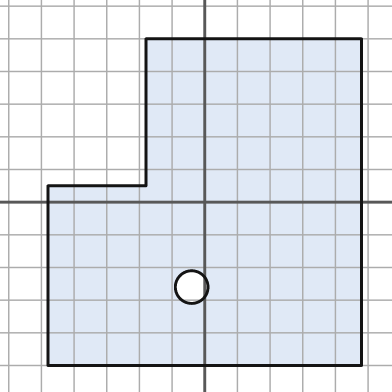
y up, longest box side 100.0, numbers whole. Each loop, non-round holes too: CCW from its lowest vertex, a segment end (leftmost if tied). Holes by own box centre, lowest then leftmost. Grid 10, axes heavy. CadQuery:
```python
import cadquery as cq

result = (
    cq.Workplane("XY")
    .moveTo(-48.0, -50.0)
    .lineTo(48.0, -50.0)
    .lineTo(48.0, 50.0)
    .lineTo(-18.0, 50.0)
    .lineTo(-18.0, 5.0)
    .lineTo(-48.0, 5.0)
    .close()
    .moveTo(-4.0, -26.0)
    .circle(5.0)
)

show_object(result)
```